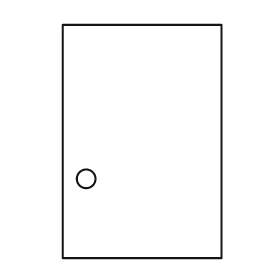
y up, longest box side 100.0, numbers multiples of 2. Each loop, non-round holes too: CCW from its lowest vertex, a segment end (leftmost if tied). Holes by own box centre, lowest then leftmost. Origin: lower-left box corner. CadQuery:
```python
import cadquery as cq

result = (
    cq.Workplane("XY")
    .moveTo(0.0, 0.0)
    .lineTo(68.0, 0.0)
    .lineTo(68.0, 100.0)
    .lineTo(0.0, 100.0)
    .close()
    .moveTo(10.0, 34.0)
    .circle(4.0)
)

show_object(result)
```